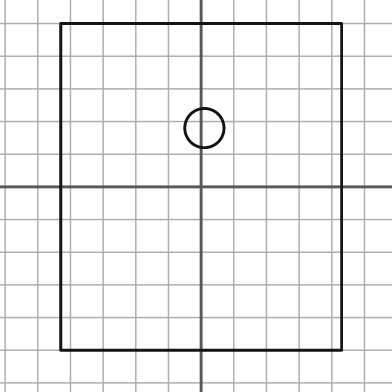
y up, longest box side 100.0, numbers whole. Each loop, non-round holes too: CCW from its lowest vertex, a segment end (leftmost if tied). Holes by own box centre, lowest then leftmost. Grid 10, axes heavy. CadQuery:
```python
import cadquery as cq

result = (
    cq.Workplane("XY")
    .moveTo(-43.0, -50.0)
    .lineTo(43.0, -50.0)
    .lineTo(43.0, 50.0)
    .lineTo(-43.0, 50.0)
    .close()
    .moveTo(1.0, 18.0)
    .circle(6.0)
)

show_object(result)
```